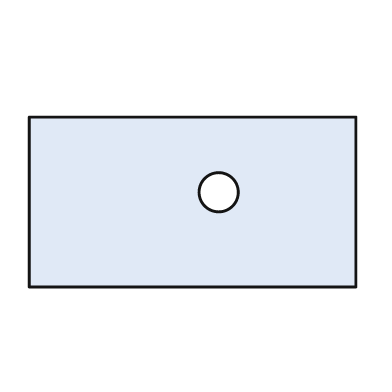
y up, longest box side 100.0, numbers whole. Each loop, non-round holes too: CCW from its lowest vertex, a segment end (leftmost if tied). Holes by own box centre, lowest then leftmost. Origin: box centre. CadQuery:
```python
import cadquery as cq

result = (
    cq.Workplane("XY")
    .moveTo(-50.0, -26.0)
    .lineTo(50.0, -26.0)
    .lineTo(50.0, 26.0)
    .lineTo(-50.0, 26.0)
    .close()
    .moveTo(8.0, 3.0)
    .circle(6.0)
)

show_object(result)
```